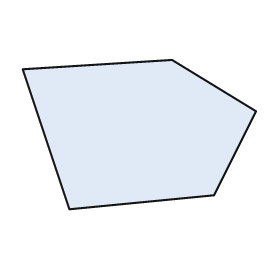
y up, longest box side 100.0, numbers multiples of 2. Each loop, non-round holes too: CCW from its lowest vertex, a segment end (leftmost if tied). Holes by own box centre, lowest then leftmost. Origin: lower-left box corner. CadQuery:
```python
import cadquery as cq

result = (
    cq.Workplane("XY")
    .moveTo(20.0, 0.0)
    .lineTo(82.0, 6.0)
    .lineTo(100.0, 42.0)
    .lineTo(64.0, 64.0)
    .lineTo(0.0, 60.0)
    .close()
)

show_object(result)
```